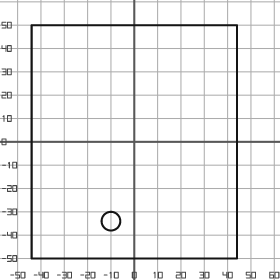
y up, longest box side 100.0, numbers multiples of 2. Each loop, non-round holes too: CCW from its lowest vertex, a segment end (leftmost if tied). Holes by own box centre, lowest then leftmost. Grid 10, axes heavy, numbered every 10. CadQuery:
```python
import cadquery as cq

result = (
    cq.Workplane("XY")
    .moveTo(-44.0, -50.0)
    .lineTo(44.0, -50.0)
    .lineTo(44.0, 50.0)
    .lineTo(-44.0, 50.0)
    .close()
    .moveTo(-10.0, -34.0)
    .circle(4.0)
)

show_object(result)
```